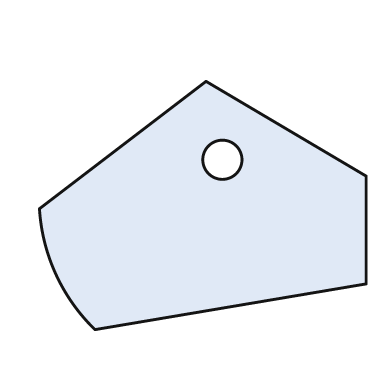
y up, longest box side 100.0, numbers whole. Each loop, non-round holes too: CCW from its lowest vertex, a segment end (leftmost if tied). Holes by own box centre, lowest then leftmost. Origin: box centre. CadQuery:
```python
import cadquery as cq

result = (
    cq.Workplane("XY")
    .moveTo(-33.0, -38.0)
    .lineTo(50.0, -24.0)
    .lineTo(50.0, 9.0)
    .lineTo(1.0, 38.0)
    .lineTo(-50.0, -1.0)
    .threePointArc((-45.0, -21.0), (-33.0, -38.0))
    .close()
    .moveTo(6.0, 14.0)
    .circle(6.0)
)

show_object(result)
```